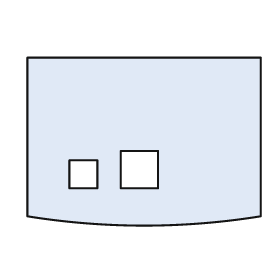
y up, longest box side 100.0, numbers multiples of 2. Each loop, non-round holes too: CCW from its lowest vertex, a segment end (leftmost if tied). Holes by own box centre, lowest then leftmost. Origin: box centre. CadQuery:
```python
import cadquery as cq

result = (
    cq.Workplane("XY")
    .moveTo(-50.0, -32.0)
    .threePointArc((0.0, -36.0), (50.0, -32.0))
    .lineTo(50.0, 36.0)
    .lineTo(-50.0, 36.0)
    .close()
    .moveTo(-32.0, -20.0)
    .lineTo(-20.0, -20.0)
    .lineTo(-20.0, -8.0)
    .lineTo(-32.0, -8.0)
    .close()
    .moveTo(-10.0, -20.0)
    .lineTo(6.0, -20.0)
    .lineTo(6.0, -4.0)
    .lineTo(-10.0, -4.0)
    .close()
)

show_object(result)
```